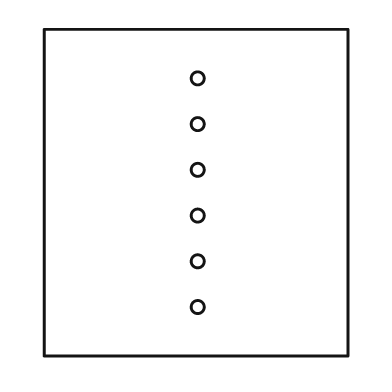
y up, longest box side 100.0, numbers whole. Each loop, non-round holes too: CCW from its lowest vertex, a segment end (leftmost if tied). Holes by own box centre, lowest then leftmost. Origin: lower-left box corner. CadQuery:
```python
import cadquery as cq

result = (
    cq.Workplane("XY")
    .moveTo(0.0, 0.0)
    .lineTo(93.0, 0.0)
    .lineTo(93.0, 100.0)
    .lineTo(0.0, 100.0)
    .close()
    .moveTo(47.0, 15.0)
    .circle(2.0)
    .moveTo(47.0, 29.0)
    .circle(2.0)
    .moveTo(47.0, 43.0)
    .circle(2.0)
    .moveTo(47.0, 57.0)
    .circle(2.0)
    .moveTo(47.0, 71.0)
    .circle(2.0)
    .moveTo(47.0, 85.0)
    .circle(2.0)
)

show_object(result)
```